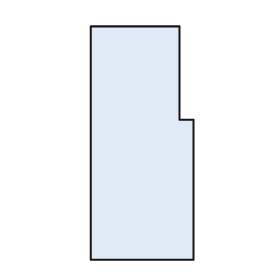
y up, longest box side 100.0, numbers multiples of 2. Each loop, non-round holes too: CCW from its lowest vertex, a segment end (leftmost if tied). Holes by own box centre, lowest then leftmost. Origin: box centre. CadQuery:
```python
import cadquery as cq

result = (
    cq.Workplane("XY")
    .moveTo(-22.0, -50.0)
    .lineTo(22.0, -50.0)
    .lineTo(22.0, 10.0)
    .lineTo(16.0, 10.0)
    .lineTo(16.0, 50.0)
    .lineTo(-22.0, 50.0)
    .close()
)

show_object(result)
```